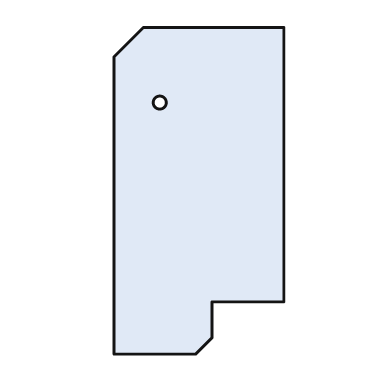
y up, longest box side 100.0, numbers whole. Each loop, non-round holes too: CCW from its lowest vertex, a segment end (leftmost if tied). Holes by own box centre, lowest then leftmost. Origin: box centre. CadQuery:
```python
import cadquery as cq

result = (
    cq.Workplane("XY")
    .moveTo(-26.0, -50.0)
    .lineTo(-1.0, -50.0)
    .lineTo(4.0, -45.0)
    .lineTo(4.0, -34.0)
    .lineTo(26.0, -34.0)
    .lineTo(26.0, 50.0)
    .lineTo(-17.0, 50.0)
    .lineTo(-26.0, 41.0)
    .close()
    .moveTo(-12.0, 27.0)
    .circle(2.0)
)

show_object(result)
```